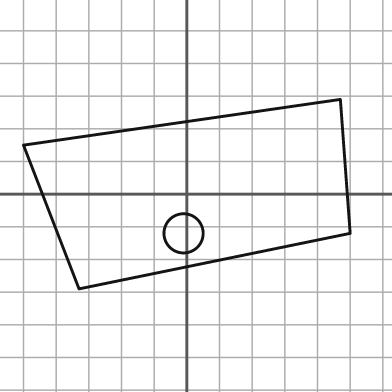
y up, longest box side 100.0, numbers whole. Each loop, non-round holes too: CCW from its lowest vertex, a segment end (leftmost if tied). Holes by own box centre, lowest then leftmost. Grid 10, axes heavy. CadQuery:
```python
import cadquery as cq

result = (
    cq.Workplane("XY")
    .moveTo(-33.0, -29.0)
    .lineTo(50.0, -12.0)
    .lineTo(47.0, 29.0)
    .lineTo(-50.0, 15.0)
    .close()
    .moveTo(-1.0, -12.0)
    .circle(6.0)
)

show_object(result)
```